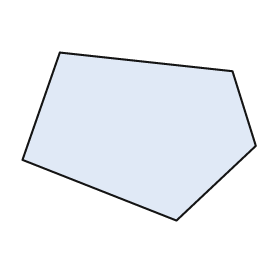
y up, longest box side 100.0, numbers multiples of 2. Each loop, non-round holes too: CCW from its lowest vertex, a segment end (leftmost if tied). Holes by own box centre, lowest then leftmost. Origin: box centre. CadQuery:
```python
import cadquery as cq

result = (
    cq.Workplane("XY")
    .moveTo(16.0, -36.0)
    .lineTo(50.0, -4.0)
    .lineTo(40.0, 28.0)
    .lineTo(-34.0, 36.0)
    .lineTo(-50.0, -10.0)
    .close()
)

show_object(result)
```